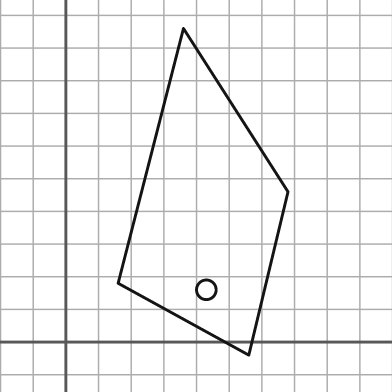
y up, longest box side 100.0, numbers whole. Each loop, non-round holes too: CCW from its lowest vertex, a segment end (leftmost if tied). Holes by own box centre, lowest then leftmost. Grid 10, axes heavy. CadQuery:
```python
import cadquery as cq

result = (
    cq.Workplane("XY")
    .moveTo(56.0, -4.0)
    .lineTo(68.0, 46.0)
    .lineTo(36.0, 96.0)
    .lineTo(16.0, 18.0)
    .close()
    .moveTo(43.0, 16.0)
    .circle(3.0)
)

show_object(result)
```